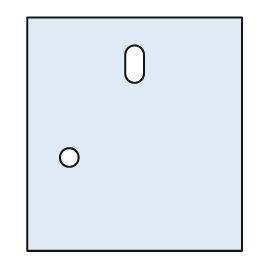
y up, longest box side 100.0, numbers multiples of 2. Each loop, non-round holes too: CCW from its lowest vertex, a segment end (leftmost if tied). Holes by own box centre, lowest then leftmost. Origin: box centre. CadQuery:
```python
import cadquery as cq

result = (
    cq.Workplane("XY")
    .moveTo(-46.0, -50.0)
    .lineTo(46.0, -50.0)
    .lineTo(46.0, 50.0)
    .lineTo(-46.0, 50.0)
    .close()
    .moveTo(-28.0, -10.0)
    .circle(4.0)
    .moveTo(-4.0, 26.0)
    .threePointArc((0.0, 22.0), (4.0, 26.0))
    .lineTo(4.0, 34.0)
    .threePointArc((0.0, 38.0), (-4.0, 34.0))
    .close()
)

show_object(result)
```